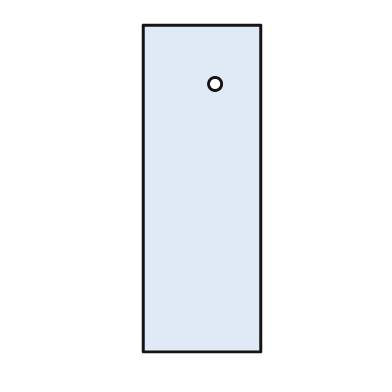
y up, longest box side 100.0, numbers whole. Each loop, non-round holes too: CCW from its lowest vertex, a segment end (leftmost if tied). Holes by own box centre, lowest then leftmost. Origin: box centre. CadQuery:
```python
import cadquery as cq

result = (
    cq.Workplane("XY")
    .moveTo(-18.0, -50.0)
    .lineTo(18.0, -50.0)
    .lineTo(18.0, 50.0)
    .lineTo(-18.0, 50.0)
    .close()
    .moveTo(4.0, 32.0)
    .circle(2.0)
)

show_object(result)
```